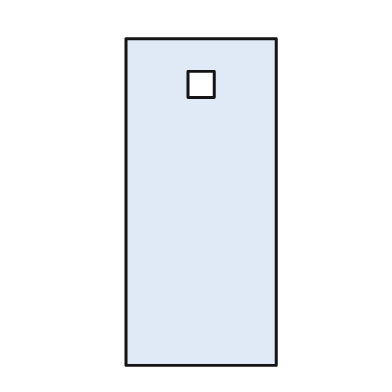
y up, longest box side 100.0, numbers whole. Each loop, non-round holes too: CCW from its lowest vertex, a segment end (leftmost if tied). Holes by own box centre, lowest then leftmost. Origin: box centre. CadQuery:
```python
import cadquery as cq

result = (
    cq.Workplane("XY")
    .moveTo(-23.0, -50.0)
    .lineTo(23.0, -50.0)
    .lineTo(23.0, 50.0)
    .lineTo(-23.0, 50.0)
    .close()
    .moveTo(-4.0, 32.0)
    .lineTo(4.0, 32.0)
    .lineTo(4.0, 40.0)
    .lineTo(-4.0, 40.0)
    .close()
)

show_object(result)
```